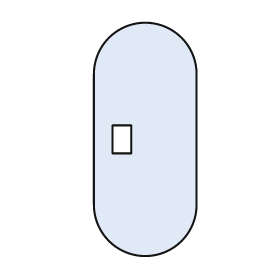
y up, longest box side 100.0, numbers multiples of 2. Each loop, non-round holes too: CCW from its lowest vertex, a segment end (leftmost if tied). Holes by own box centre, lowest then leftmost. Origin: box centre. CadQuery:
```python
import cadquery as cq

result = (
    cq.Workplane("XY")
    .moveTo(-22.0, -28.0)
    .threePointArc((0.0, -50.0), (22.0, -28.0))
    .lineTo(22.0, 28.0)
    .threePointArc((0.0, 50.0), (-22.0, 28.0))
    .close()
    .moveTo(-14.0, -6.0)
    .lineTo(-6.0, -6.0)
    .lineTo(-6.0, 6.0)
    .lineTo(-14.0, 6.0)
    .close()
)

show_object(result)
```